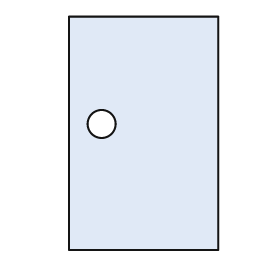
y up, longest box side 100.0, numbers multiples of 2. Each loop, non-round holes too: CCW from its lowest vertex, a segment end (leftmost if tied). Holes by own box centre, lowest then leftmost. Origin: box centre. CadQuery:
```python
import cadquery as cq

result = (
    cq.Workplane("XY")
    .moveTo(-32.0, -50.0)
    .lineTo(32.0, -50.0)
    .lineTo(32.0, 50.0)
    .lineTo(-32.0, 50.0)
    .close()
    .moveTo(-18.0, 4.0)
    .circle(6.0)
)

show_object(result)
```